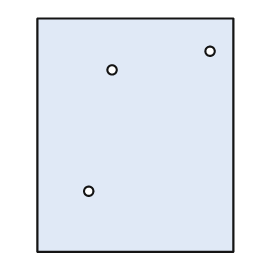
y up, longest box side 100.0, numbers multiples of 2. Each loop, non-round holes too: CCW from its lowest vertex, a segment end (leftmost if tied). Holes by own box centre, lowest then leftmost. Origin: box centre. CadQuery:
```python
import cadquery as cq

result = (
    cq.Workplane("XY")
    .moveTo(-42.0, -50.0)
    .lineTo(42.0, -50.0)
    .lineTo(42.0, 50.0)
    .lineTo(-42.0, 50.0)
    .close()
    .moveTo(-20.0, -24.0)
    .circle(2.0)
    .moveTo(-10.0, 28.0)
    .circle(2.0)
    .moveTo(32.0, 36.0)
    .circle(2.0)
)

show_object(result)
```